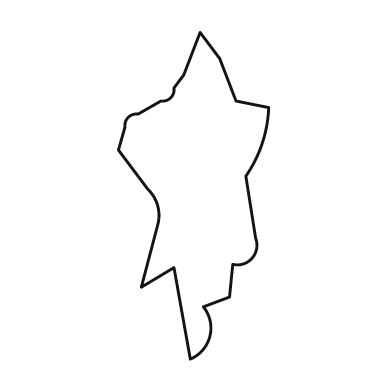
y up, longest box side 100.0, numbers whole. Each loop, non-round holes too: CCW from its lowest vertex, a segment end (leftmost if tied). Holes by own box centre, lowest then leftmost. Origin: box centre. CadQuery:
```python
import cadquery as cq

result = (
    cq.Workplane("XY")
    .moveTo(-1.0, -50.0)
    .threePointArc((5.0, -43.0), (3.0, -34.0))
    .lineTo(11.0, -31.0)
    .lineTo(12.0, -21.0)
    .threePointArc((18.0, -19.0), (19.0, -13.0))
    .lineTo(16.0, 6.0)
    .threePointArc((21.0, 16.0), (23.0, 27.0))
    .lineTo(13.0, 29.0)
    .lineTo(8.0, 42.0)
    .lineTo(2.0, 50.0)
    .lineTo(-3.0, 37.0)
    .lineTo(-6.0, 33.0)
    .threePointArc((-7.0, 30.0), (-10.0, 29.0))
    .lineTo(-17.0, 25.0)
    .threePointArc((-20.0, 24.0), (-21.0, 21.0))
    .lineTo(-23.0, 14.0)
    .lineTo(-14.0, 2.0)
    .threePointArc((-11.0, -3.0), (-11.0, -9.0))
    .lineTo(-16.0, -28.0)
    .lineTo(-6.0, -22.0)
    .close()
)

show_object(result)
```